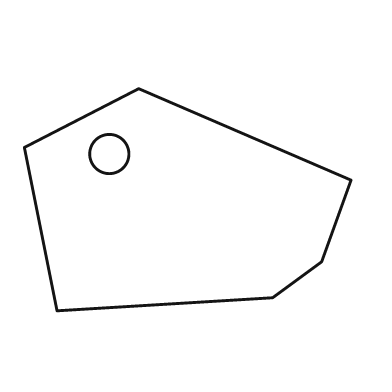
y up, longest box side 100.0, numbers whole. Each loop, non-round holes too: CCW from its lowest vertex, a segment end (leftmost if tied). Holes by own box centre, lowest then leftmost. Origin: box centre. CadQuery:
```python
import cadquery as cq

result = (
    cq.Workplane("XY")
    .moveTo(-40.0, -34.0)
    .lineTo(26.0, -30.0)
    .lineTo(41.0, -19.0)
    .lineTo(50.0, 6.0)
    .lineTo(-15.0, 34.0)
    .lineTo(-50.0, 16.0)
    .close()
    .moveTo(-24.0, 14.0)
    .circle(6.0)
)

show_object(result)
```